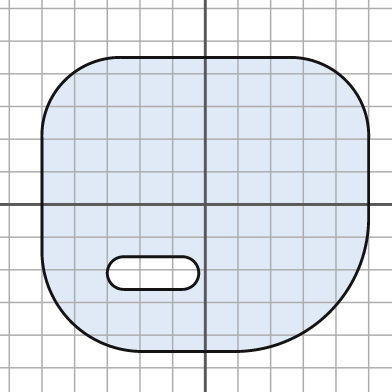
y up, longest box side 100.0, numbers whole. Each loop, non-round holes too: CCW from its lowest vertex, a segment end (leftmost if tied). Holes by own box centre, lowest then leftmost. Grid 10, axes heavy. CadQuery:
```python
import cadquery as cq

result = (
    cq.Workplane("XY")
    .moveTo(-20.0, -45.0)
    .lineTo(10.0, -45.0)
    .threePointArc((38.0, -33.0), (50.0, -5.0))
    .lineTo(50.0, 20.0)
    .threePointArc((43.0, 38.0), (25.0, 45.0))
    .lineTo(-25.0, 45.0)
    .threePointArc((-43.0, 38.0), (-50.0, 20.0))
    .lineTo(-50.0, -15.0)
    .threePointArc((-41.0, -36.0), (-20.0, -45.0))
    .close()
    .moveTo(-25.0, -26.0)
    .lineTo(-7.0, -26.0)
    .threePointArc((-2.0, -21.0), (-7.0, -16.0))
    .lineTo(-25.0, -16.0)
    .threePointArc((-30.0, -21.0), (-25.0, -26.0))
    .close()
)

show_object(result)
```